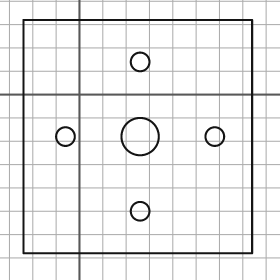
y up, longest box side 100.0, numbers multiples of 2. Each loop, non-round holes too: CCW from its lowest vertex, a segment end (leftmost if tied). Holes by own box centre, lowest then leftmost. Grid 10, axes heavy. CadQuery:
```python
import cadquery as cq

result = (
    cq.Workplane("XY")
    .moveTo(-24.0, -68.0)
    .lineTo(74.0, -68.0)
    .lineTo(74.0, 32.0)
    .lineTo(-24.0, 32.0)
    .close()
    .moveTo(26.0, -50.0)
    .circle(4.0)
    .moveTo(-6.0, -18.0)
    .circle(4.0)
    .moveTo(26.0, -18.0)
    .circle(8.0)
    .moveTo(58.0, -18.0)
    .circle(4.0)
    .moveTo(26.0, 14.0)
    .circle(4.0)
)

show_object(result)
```